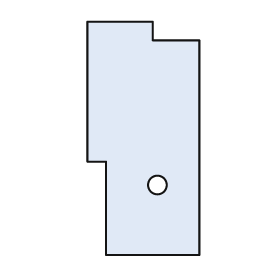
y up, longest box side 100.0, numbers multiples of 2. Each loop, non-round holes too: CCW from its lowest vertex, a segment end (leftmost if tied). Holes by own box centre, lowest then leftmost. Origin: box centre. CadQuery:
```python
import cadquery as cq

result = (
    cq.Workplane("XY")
    .moveTo(-16.0, -50.0)
    .lineTo(24.0, -50.0)
    .lineTo(24.0, 42.0)
    .lineTo(4.0, 42.0)
    .lineTo(4.0, 50.0)
    .lineTo(-24.0, 50.0)
    .lineTo(-24.0, -10.0)
    .lineTo(-16.0, -10.0)
    .close()
    .moveTo(6.0, -20.0)
    .circle(4.0)
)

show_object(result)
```